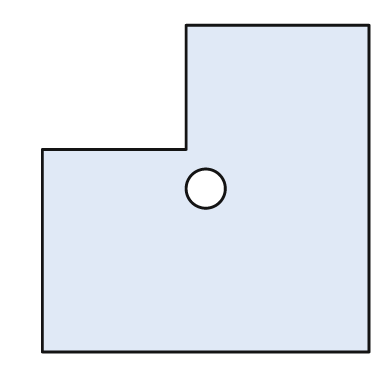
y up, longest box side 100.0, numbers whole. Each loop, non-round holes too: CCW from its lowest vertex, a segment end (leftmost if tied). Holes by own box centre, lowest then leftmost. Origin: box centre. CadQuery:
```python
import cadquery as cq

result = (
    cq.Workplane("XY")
    .moveTo(-50.0, -50.0)
    .lineTo(50.0, -50.0)
    .lineTo(50.0, 50.0)
    .lineTo(-6.0, 50.0)
    .lineTo(-6.0, 12.0)
    .lineTo(-50.0, 12.0)
    .close()
    .moveTo(0.0, 0.0)
    .circle(6.0)
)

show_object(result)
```